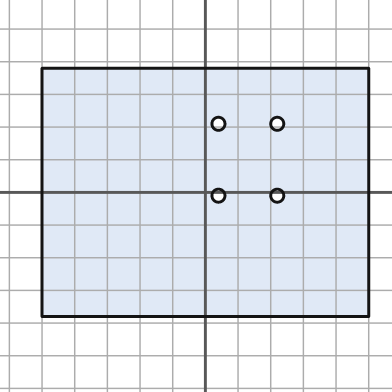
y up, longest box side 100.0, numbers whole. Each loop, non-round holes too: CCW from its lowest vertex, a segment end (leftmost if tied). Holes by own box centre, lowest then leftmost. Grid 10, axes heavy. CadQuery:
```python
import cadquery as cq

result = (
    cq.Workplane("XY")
    .moveTo(-50.0, -38.0)
    .lineTo(50.0, -38.0)
    .lineTo(50.0, 38.0)
    .lineTo(-50.0, 38.0)
    .close()
    .moveTo(4.0, -1.0)
    .circle(2.0)
    .moveTo(22.0, -1.0)
    .circle(2.0)
    .moveTo(4.0, 21.0)
    .circle(2.0)
    .moveTo(22.0, 21.0)
    .circle(2.0)
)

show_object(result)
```